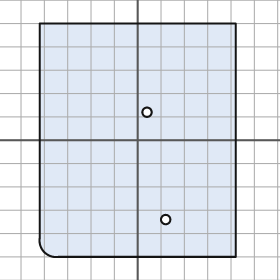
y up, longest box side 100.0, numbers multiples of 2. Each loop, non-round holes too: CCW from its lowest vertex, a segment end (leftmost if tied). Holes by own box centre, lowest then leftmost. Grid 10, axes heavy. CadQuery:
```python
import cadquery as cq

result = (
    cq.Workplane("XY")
    .moveTo(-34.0, -50.0)
    .lineTo(42.0, -50.0)
    .lineTo(42.0, 50.0)
    .lineTo(-42.0, 50.0)
    .lineTo(-42.0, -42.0)
    .threePointArc((-40.0, -48.0), (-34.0, -50.0))
    .close()
    .moveTo(12.0, -34.0)
    .circle(2.0)
    .moveTo(4.0, 12.0)
    .circle(2.0)
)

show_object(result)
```